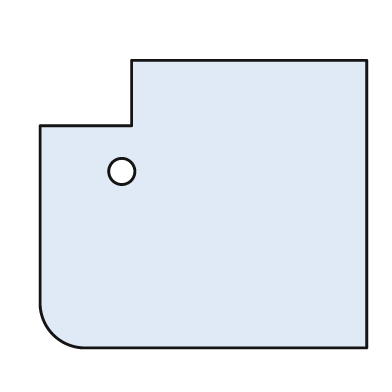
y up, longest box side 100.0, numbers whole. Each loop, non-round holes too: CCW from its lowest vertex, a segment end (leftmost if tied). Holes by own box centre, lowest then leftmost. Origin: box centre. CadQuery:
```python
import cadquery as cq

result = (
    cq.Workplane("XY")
    .moveTo(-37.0, -44.0)
    .lineTo(50.0, -44.0)
    .lineTo(50.0, 44.0)
    .lineTo(-22.0, 44.0)
    .lineTo(-22.0, 24.0)
    .lineTo(-50.0, 24.0)
    .lineTo(-50.0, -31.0)
    .threePointArc((-46.0, -40.0), (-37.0, -44.0))
    .close()
    .moveTo(-25.0, 10.0)
    .circle(4.0)
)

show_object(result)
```